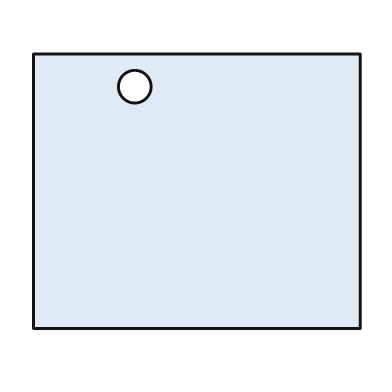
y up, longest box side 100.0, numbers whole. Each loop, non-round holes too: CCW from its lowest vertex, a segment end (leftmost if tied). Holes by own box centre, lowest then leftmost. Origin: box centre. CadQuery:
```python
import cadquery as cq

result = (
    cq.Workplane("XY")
    .moveTo(-50.0, -42.0)
    .lineTo(50.0, -42.0)
    .lineTo(50.0, 42.0)
    .lineTo(-50.0, 42.0)
    .close()
    .moveTo(-19.0, 32.0)
    .circle(5.0)
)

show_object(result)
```